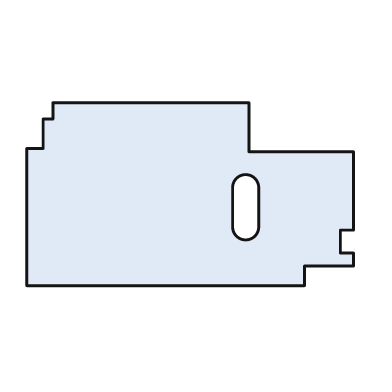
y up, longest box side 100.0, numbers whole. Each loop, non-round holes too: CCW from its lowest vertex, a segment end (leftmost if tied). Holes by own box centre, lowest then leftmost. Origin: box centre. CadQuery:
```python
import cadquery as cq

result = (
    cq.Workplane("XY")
    .moveTo(-50.0, -28.0)
    .lineTo(35.0, -28.0)
    .lineTo(35.0, -22.0)
    .lineTo(50.0, -22.0)
    .lineTo(50.0, -18.0)
    .lineTo(46.0, -18.0)
    .lineTo(46.0, -11.0)
    .lineTo(50.0, -11.0)
    .lineTo(50.0, 13.0)
    .lineTo(18.0, 13.0)
    .lineTo(18.0, 28.0)
    .lineTo(-42.0, 28.0)
    .lineTo(-42.0, 23.0)
    .lineTo(-45.0, 23.0)
    .lineTo(-45.0, 14.0)
    .lineTo(-50.0, 14.0)
    .close()
    .moveTo(13.0, -10.0)
    .threePointArc((17.0, -14.0), (21.0, -10.0))
    .lineTo(21.0, 2.0)
    .threePointArc((17.0, 6.0), (13.0, 2.0))
    .close()
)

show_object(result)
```